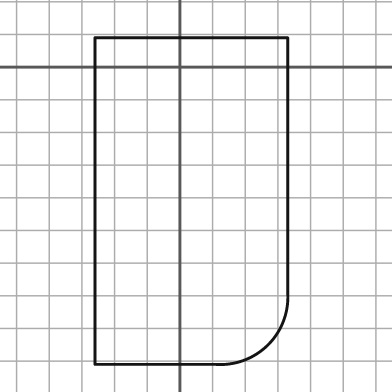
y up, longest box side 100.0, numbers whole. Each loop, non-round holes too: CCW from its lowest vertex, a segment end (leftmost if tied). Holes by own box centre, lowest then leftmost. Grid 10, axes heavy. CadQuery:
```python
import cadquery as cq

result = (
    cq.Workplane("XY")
    .moveTo(-26.0, -91.0)
    .lineTo(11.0, -91.0)
    .threePointArc((27.0, -85.0), (33.0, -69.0))
    .lineTo(33.0, 9.0)
    .lineTo(-26.0, 9.0)
    .close()
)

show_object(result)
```